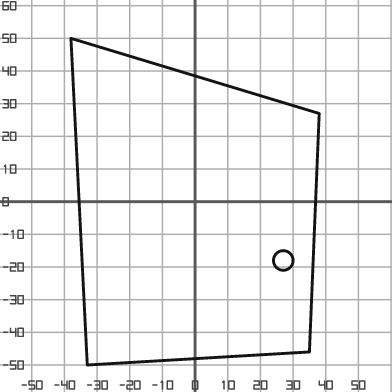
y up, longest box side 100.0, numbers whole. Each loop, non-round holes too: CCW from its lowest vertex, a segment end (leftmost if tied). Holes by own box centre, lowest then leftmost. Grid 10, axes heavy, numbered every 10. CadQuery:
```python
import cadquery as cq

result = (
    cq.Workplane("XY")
    .moveTo(-33.0, -50.0)
    .lineTo(35.0, -46.0)
    .lineTo(38.0, 27.0)
    .lineTo(-38.0, 50.0)
    .close()
    .moveTo(27.0, -18.0)
    .circle(3.0)
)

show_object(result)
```